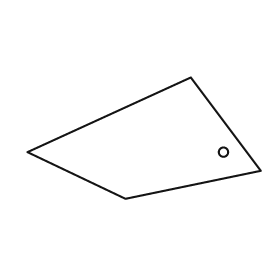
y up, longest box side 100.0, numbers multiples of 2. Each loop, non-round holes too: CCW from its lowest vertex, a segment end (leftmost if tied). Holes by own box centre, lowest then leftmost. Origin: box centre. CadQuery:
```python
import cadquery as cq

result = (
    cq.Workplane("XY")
    .moveTo(-8.0, -26.0)
    .lineTo(50.0, -14.0)
    .lineTo(20.0, 26.0)
    .lineTo(-50.0, -6.0)
    .close()
    .moveTo(34.0, -6.0)
    .circle(2.0)
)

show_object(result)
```